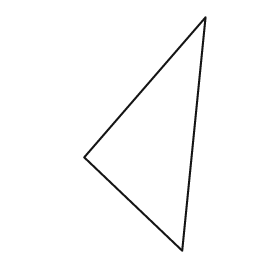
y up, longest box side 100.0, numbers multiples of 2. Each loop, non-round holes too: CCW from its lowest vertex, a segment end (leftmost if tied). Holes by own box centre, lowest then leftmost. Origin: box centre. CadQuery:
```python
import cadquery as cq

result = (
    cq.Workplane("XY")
    .moveTo(16.0, -50.0)
    .lineTo(26.0, 50.0)
    .lineTo(-26.0, -10.0)
    .close()
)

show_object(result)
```